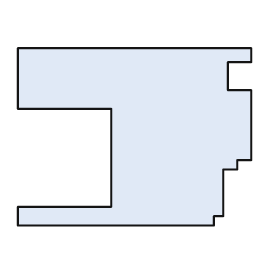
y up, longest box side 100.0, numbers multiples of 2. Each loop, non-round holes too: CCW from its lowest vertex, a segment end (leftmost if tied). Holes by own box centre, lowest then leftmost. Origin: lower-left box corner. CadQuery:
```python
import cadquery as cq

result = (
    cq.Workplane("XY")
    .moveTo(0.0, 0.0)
    .lineTo(84.0, 0.0)
    .lineTo(84.0, 4.0)
    .lineTo(88.0, 4.0)
    .lineTo(88.0, 24.0)
    .lineTo(94.0, 24.0)
    .lineTo(94.0, 28.0)
    .lineTo(100.0, 28.0)
    .lineTo(100.0, 58.0)
    .lineTo(90.0, 58.0)
    .lineTo(90.0, 70.0)
    .lineTo(100.0, 70.0)
    .lineTo(100.0, 76.0)
    .lineTo(0.0, 76.0)
    .lineTo(0.0, 50.0)
    .lineTo(40.0, 50.0)
    .lineTo(40.0, 8.0)
    .lineTo(0.0, 8.0)
    .close()
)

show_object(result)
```